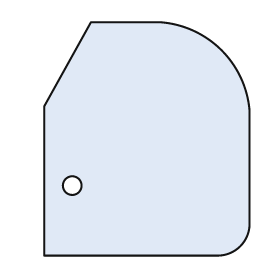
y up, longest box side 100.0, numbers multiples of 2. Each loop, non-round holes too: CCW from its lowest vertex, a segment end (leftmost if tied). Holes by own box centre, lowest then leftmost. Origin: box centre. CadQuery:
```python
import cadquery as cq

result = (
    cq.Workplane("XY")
    .moveTo(-44.0, -50.0)
    .lineTo(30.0, -50.0)
    .threePointArc((40.0, -46.0), (44.0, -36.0))
    .lineTo(44.0, 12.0)
    .threePointArc((32.0, 38.0), (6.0, 50.0))
    .lineTo(-24.0, 50.0)
    .lineTo(-44.0, 14.0)
    .close()
    .moveTo(-32.0, -20.0)
    .circle(4.0)
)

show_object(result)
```